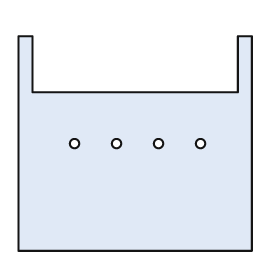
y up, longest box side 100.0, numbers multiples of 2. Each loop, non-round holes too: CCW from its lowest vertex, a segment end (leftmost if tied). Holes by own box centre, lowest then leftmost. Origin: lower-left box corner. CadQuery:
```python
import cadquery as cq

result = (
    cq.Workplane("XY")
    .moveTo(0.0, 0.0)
    .lineTo(100.0, 0.0)
    .lineTo(100.0, 92.0)
    .lineTo(94.0, 92.0)
    .lineTo(94.0, 68.0)
    .lineTo(6.0, 68.0)
    .lineTo(6.0, 92.0)
    .lineTo(0.0, 92.0)
    .close()
    .moveTo(24.0, 46.0)
    .circle(2.0)
    .moveTo(42.0, 46.0)
    .circle(2.0)
    .moveTo(60.0, 46.0)
    .circle(2.0)
    .moveTo(78.0, 46.0)
    .circle(2.0)
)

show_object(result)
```